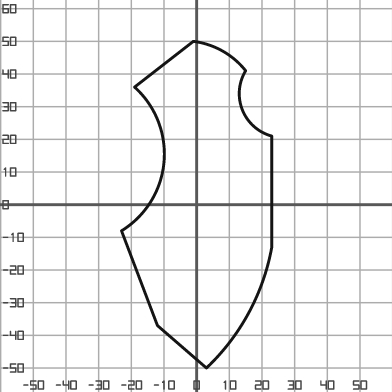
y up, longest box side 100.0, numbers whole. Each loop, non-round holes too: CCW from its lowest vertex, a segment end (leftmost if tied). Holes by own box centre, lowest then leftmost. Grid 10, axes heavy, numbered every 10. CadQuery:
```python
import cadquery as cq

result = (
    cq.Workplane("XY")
    .moveTo(3.0, -50.0)
    .threePointArc((16.0, -33.0), (23.0, -13.0))
    .lineTo(23.0, 21.0)
    .threePointArc((14.0, 29.0), (15.0, 41.0))
    .threePointArc((8.0, 47.0), (-1.0, 50.0))
    .lineTo(-19.0, 36.0)
    .threePointArc((-10.0, 13.0), (-23.0, -8.0))
    .lineTo(-12.0, -37.0)
    .close()
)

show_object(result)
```